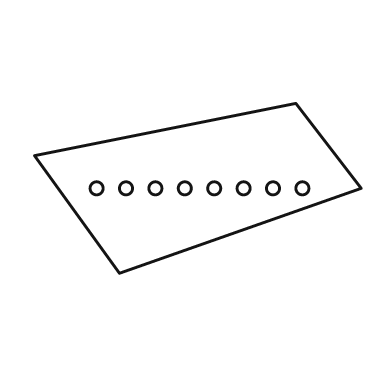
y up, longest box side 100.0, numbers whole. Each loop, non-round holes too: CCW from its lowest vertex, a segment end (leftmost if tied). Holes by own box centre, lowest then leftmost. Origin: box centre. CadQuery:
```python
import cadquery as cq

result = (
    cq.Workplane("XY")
    .moveTo(-24.0, -26.0)
    .lineTo(50.0, 0.0)
    .lineTo(30.0, 26.0)
    .lineTo(-50.0, 10.0)
    .close()
    .moveTo(-31.0, 0.0)
    .circle(2.0)
    .moveTo(-22.0, 0.0)
    .circle(2.0)
    .moveTo(-13.0, 0.0)
    .circle(2.0)
    .moveTo(-4.0, 0.0)
    .circle(2.0)
    .moveTo(5.0, 0.0)
    .circle(2.0)
    .moveTo(14.0, 0.0)
    .circle(2.0)
    .moveTo(23.0, 0.0)
    .circle(2.0)
    .moveTo(32.0, 0.0)
    .circle(2.0)
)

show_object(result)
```